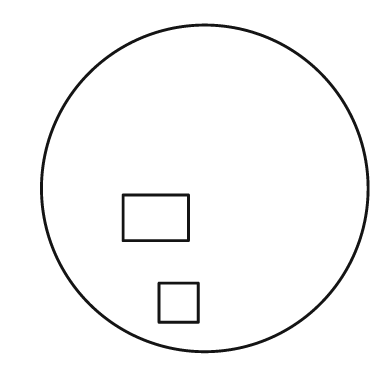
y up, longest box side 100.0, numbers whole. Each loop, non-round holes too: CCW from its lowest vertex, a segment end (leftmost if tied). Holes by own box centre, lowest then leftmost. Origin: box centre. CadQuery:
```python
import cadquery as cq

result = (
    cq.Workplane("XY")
    .moveTo(0.0, 0.0)
    .circle(50.0)
    .moveTo(-14.0, -41.0)
    .lineTo(-2.0, -41.0)
    .lineTo(-2.0, -29.0)
    .lineTo(-14.0, -29.0)
    .close()
    .moveTo(-25.0, -16.0)
    .lineTo(-5.0, -16.0)
    .lineTo(-5.0, -2.0)
    .lineTo(-25.0, -2.0)
    .close()
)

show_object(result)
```